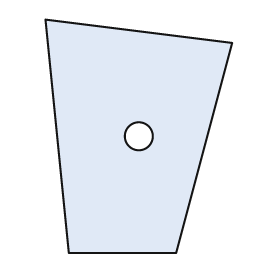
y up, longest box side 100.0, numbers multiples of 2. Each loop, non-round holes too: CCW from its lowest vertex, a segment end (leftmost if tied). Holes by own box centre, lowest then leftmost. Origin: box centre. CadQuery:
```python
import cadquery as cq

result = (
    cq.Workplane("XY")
    .moveTo(-30.0, -50.0)
    .lineTo(16.0, -50.0)
    .lineTo(40.0, 40.0)
    .lineTo(-40.0, 50.0)
    .close()
    .moveTo(0.0, 0.0)
    .circle(6.0)
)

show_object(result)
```